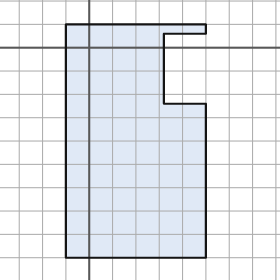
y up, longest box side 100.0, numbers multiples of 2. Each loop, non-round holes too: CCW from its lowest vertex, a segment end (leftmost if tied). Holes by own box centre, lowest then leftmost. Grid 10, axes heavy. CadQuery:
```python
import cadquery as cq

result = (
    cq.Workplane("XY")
    .moveTo(-10.0, -90.0)
    .lineTo(50.0, -90.0)
    .lineTo(50.0, -24.0)
    .lineTo(32.0, -24.0)
    .lineTo(32.0, 6.0)
    .lineTo(50.0, 6.0)
    .lineTo(50.0, 10.0)
    .lineTo(-10.0, 10.0)
    .close()
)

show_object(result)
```